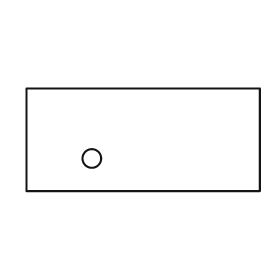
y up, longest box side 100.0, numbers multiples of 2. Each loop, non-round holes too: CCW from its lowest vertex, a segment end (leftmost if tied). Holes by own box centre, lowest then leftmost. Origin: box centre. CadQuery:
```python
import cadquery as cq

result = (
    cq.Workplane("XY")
    .moveTo(-50.0, -22.0)
    .lineTo(50.0, -22.0)
    .lineTo(50.0, 22.0)
    .lineTo(-50.0, 22.0)
    .close()
    .moveTo(-22.0, -8.0)
    .circle(4.0)
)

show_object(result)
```